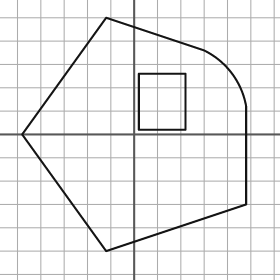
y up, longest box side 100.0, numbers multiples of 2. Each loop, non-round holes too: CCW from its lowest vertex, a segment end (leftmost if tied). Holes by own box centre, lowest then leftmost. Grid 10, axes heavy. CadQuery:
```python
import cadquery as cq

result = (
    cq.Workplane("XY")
    .moveTo(-12.0, -50.0)
    .lineTo(48.0, -30.0)
    .lineTo(48.0, 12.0)
    .threePointArc((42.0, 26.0), (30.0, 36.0))
    .lineTo(-12.0, 50.0)
    .lineTo(-48.0, 0.0)
    .close()
    .moveTo(2.0, 2.0)
    .lineTo(22.0, 2.0)
    .lineTo(22.0, 26.0)
    .lineTo(2.0, 26.0)
    .close()
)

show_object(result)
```